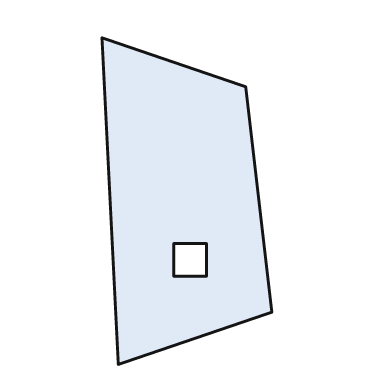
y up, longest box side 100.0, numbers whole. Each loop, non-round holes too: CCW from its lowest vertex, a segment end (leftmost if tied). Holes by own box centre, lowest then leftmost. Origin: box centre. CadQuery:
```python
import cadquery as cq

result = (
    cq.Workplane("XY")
    .moveTo(-21.0, -50.0)
    .lineTo(26.0, -34.0)
    .lineTo(18.0, 35.0)
    .lineTo(-26.0, 50.0)
    .close()
    .moveTo(-4.0, -23.0)
    .lineTo(6.0, -23.0)
    .lineTo(6.0, -13.0)
    .lineTo(-4.0, -13.0)
    .close()
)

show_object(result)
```